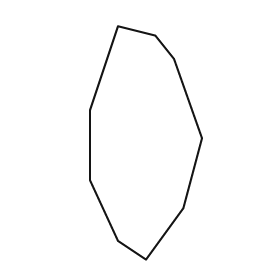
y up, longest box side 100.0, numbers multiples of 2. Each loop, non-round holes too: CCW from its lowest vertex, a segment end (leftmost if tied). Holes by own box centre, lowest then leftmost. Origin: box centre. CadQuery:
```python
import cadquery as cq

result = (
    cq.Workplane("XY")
    .moveTo(0.0, -50.0)
    .lineTo(16.0, -28.0)
    .lineTo(24.0, 2.0)
    .lineTo(12.0, 36.0)
    .lineTo(4.0, 46.0)
    .lineTo(-12.0, 50.0)
    .lineTo(-24.0, 14.0)
    .lineTo(-24.0, -16.0)
    .lineTo(-12.0, -42.0)
    .close()
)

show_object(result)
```